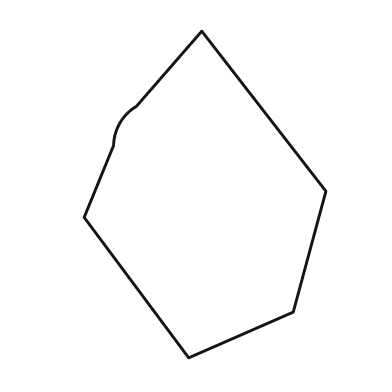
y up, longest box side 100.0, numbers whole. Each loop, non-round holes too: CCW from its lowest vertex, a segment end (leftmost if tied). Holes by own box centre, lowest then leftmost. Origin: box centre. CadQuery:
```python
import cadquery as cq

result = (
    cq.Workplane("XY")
    .moveTo(-5.0, -50.0)
    .lineTo(27.0, -36.0)
    .lineTo(37.0, 1.0)
    .lineTo(-1.0, 50.0)
    .lineTo(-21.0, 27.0)
    .threePointArc((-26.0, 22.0), (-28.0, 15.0))
    .lineTo(-37.0, -7.0)
    .close()
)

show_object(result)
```